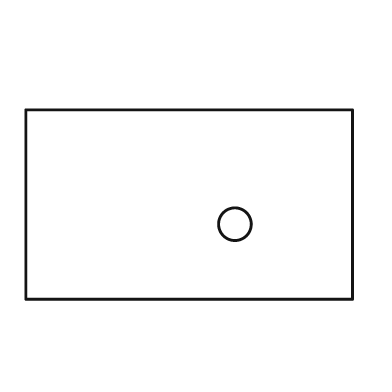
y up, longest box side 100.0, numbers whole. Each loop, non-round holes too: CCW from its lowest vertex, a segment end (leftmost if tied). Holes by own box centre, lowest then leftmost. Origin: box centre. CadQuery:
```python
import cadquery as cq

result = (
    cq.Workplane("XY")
    .moveTo(-50.0, -29.0)
    .lineTo(50.0, -29.0)
    .lineTo(50.0, 29.0)
    .lineTo(-50.0, 29.0)
    .close()
    .moveTo(14.0, -6.0)
    .circle(5.0)
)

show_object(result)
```